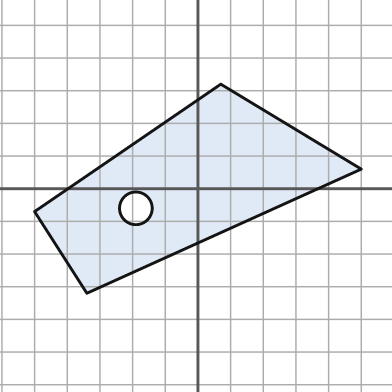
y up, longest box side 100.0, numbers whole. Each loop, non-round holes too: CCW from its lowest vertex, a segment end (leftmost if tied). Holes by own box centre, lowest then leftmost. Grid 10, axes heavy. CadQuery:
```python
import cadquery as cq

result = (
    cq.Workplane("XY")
    .moveTo(-34.0, -32.0)
    .lineTo(50.0, 6.0)
    .lineTo(7.0, 32.0)
    .lineTo(-50.0, -7.0)
    .close()
    .moveTo(-19.0, -6.0)
    .circle(5.0)
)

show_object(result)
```